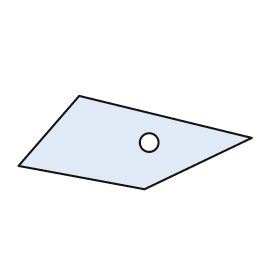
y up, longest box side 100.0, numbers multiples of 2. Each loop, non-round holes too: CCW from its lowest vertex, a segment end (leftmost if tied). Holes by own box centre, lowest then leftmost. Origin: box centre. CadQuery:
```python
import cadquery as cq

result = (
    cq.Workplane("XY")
    .moveTo(4.0, -20.0)
    .lineTo(50.0, 2.0)
    .lineTo(-24.0, 20.0)
    .lineTo(-50.0, -10.0)
    .close()
    .moveTo(6.0, 0.0)
    .circle(4.0)
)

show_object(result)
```